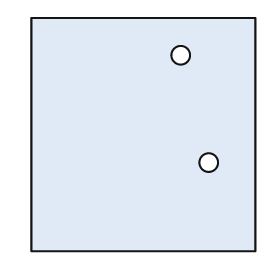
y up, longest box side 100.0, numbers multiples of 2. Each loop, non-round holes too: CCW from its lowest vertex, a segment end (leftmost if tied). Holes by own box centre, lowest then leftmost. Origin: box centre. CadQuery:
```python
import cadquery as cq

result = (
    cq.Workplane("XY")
    .moveTo(-48.0, -50.0)
    .lineTo(48.0, -50.0)
    .lineTo(48.0, 50.0)
    .lineTo(-48.0, 50.0)
    .close()
    .moveTo(28.0, -12.0)
    .circle(4.0)
    .moveTo(16.0, 34.0)
    .circle(4.0)
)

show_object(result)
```